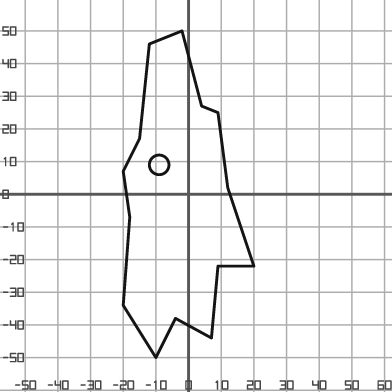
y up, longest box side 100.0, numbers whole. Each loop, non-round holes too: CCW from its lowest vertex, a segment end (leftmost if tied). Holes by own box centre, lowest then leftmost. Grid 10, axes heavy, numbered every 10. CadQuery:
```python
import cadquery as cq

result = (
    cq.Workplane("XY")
    .moveTo(-10.0, -50.0)
    .lineTo(-4.0, -38.0)
    .lineTo(7.0, -44.0)
    .lineTo(9.0, -22.0)
    .lineTo(20.0, -22.0)
    .lineTo(12.0, 2.0)
    .lineTo(9.0, 25.0)
    .lineTo(4.0, 27.0)
    .lineTo(-2.0, 50.0)
    .lineTo(-12.0, 46.0)
    .lineTo(-15.0, 17.0)
    .lineTo(-20.0, 7.0)
    .lineTo(-18.0, -7.0)
    .lineTo(-20.0, -34.0)
    .close()
    .moveTo(-9.0, 9.0)
    .circle(3.0)
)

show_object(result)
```